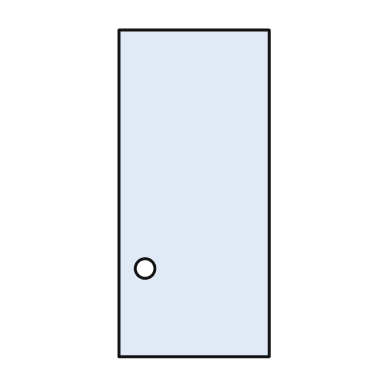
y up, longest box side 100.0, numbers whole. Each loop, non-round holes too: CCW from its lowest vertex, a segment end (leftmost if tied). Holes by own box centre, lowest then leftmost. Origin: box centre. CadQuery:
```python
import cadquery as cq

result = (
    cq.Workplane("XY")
    .moveTo(-23.0, -50.0)
    .lineTo(23.0, -50.0)
    .lineTo(23.0, 50.0)
    .lineTo(-23.0, 50.0)
    .close()
    .moveTo(-15.0, -23.0)
    .circle(3.0)
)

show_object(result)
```